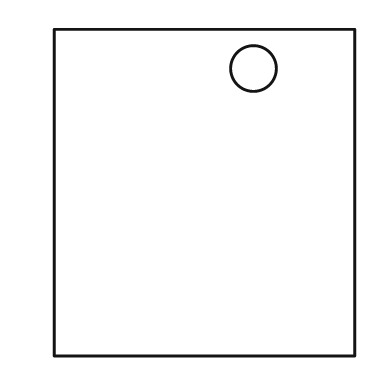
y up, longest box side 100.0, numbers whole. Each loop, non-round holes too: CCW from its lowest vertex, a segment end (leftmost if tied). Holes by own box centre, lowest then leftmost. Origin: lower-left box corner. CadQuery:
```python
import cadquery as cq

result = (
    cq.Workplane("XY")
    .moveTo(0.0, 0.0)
    .lineTo(92.0, 0.0)
    .lineTo(92.0, 100.0)
    .lineTo(0.0, 100.0)
    .close()
    .moveTo(61.0, 88.0)
    .circle(7.0)
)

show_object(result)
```